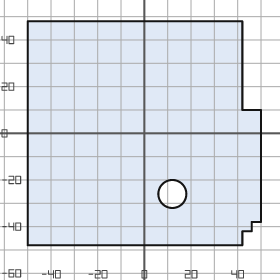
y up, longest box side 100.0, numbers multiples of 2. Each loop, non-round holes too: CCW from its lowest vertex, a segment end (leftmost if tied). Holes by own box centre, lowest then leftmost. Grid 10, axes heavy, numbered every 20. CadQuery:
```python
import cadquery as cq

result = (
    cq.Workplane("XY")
    .moveTo(-50.0, -48.0)
    .lineTo(42.0, -48.0)
    .lineTo(42.0, -42.0)
    .lineTo(46.0, -42.0)
    .lineTo(46.0, -38.0)
    .lineTo(50.0, -38.0)
    .lineTo(50.0, 10.0)
    .lineTo(42.0, 10.0)
    .lineTo(42.0, 48.0)
    .lineTo(-50.0, 48.0)
    .close()
    .moveTo(12.0, -26.0)
    .circle(6.0)
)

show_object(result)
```